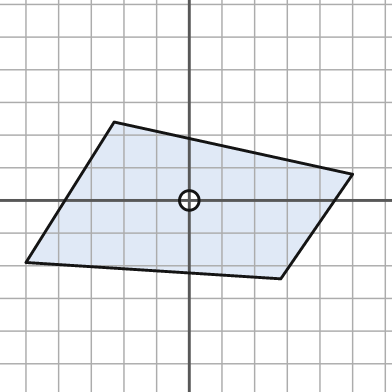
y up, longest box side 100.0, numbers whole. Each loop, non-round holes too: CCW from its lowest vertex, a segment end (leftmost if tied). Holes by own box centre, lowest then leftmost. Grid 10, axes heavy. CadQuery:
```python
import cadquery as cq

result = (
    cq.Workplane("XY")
    .moveTo(28.0, -24.0)
    .lineTo(50.0, 8.0)
    .lineTo(-23.0, 24.0)
    .lineTo(-50.0, -19.0)
    .close()
    .moveTo(0.0, 0.0)
    .circle(3.0)
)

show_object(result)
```